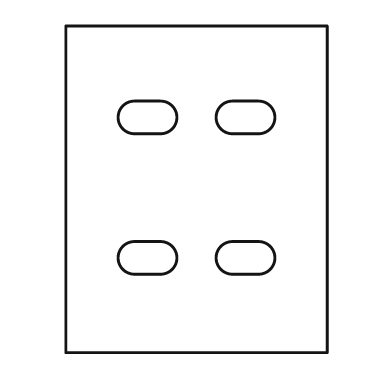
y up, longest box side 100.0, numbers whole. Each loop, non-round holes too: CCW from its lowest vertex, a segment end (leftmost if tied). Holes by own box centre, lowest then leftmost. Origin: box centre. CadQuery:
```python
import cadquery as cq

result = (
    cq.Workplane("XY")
    .moveTo(-40.0, -50.0)
    .lineTo(40.0, -50.0)
    .lineTo(40.0, 50.0)
    .lineTo(-40.0, 50.0)
    .close()
    .moveTo(-19.0, -26.0)
    .lineTo(-11.0, -26.0)
    .threePointArc((-6.0, -21.0), (-11.0, -16.0))
    .lineTo(-19.0, -16.0)
    .threePointArc((-24.0, -21.0), (-19.0, -26.0))
    .close()
    .moveTo(11.0, -26.0)
    .lineTo(19.0, -26.0)
    .threePointArc((24.0, -21.0), (19.0, -16.0))
    .lineTo(11.0, -16.0)
    .threePointArc((6.0, -21.0), (11.0, -26.0))
    .close()
    .moveTo(-19.0, 17.0)
    .lineTo(-11.0, 17.0)
    .threePointArc((-6.0, 22.0), (-11.0, 27.0))
    .lineTo(-19.0, 27.0)
    .threePointArc((-24.0, 22.0), (-19.0, 17.0))
    .close()
    .moveTo(11.0, 17.0)
    .lineTo(19.0, 17.0)
    .threePointArc((24.0, 22.0), (19.0, 27.0))
    .lineTo(11.0, 27.0)
    .threePointArc((6.0, 22.0), (11.0, 17.0))
    .close()
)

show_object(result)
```